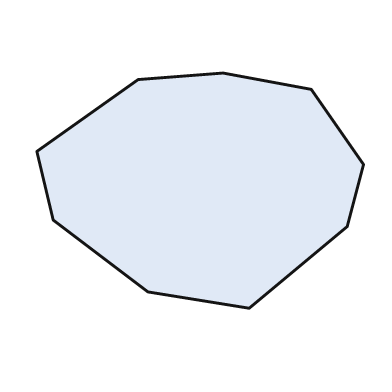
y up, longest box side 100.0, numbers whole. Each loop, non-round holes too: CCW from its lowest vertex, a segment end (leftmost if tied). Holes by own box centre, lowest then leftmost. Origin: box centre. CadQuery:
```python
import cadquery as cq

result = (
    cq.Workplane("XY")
    .moveTo(15.0, -36.0)
    .lineTo(45.0, -11.0)
    .lineTo(50.0, 8.0)
    .lineTo(34.0, 31.0)
    .lineTo(7.0, 36.0)
    .lineTo(-19.0, 34.0)
    .lineTo(-50.0, 12.0)
    .lineTo(-45.0, -9.0)
    .lineTo(-16.0, -31.0)
    .close()
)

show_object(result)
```